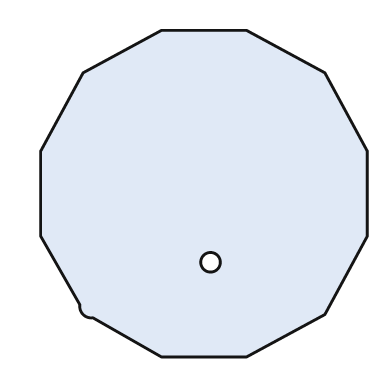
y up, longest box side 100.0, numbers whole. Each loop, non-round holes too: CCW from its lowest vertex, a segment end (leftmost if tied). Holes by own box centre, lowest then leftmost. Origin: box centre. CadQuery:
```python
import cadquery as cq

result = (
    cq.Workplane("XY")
    .moveTo(-13.0, -50.0)
    .lineTo(13.0, -50.0)
    .lineTo(37.0, -37.0)
    .lineTo(50.0, -13.0)
    .lineTo(50.0, 13.0)
    .lineTo(37.0, 37.0)
    .lineTo(13.0, 50.0)
    .lineTo(-13.0, 50.0)
    .lineTo(-37.0, 37.0)
    .lineTo(-50.0, 13.0)
    .lineTo(-50.0, -13.0)
    .lineTo(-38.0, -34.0)
    .threePointArc((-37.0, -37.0), (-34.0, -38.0))
    .close()
    .moveTo(2.0, -21.0)
    .circle(3.0)
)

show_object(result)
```